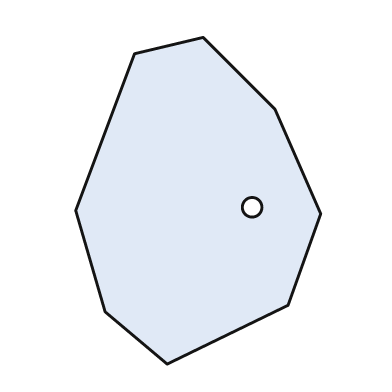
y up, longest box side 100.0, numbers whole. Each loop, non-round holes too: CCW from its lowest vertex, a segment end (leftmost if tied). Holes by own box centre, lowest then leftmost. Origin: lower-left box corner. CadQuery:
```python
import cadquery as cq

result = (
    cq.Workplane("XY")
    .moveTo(28.0, 0.0)
    .lineTo(65.0, 18.0)
    .lineTo(75.0, 46.0)
    .lineTo(61.0, 78.0)
    .lineTo(39.0, 100.0)
    .lineTo(18.0, 95.0)
    .lineTo(0.0, 47.0)
    .lineTo(9.0, 16.0)
    .close()
    .moveTo(54.0, 48.0)
    .circle(3.0)
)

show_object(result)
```